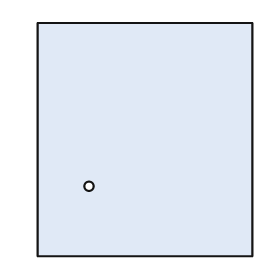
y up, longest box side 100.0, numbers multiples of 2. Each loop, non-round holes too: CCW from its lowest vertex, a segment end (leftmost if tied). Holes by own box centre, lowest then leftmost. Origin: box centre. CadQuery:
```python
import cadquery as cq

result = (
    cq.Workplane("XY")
    .moveTo(-46.0, -50.0)
    .lineTo(46.0, -50.0)
    .lineTo(46.0, 50.0)
    .lineTo(-46.0, 50.0)
    .close()
    .moveTo(-24.0, -20.0)
    .circle(2.0)
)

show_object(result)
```